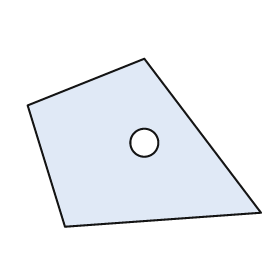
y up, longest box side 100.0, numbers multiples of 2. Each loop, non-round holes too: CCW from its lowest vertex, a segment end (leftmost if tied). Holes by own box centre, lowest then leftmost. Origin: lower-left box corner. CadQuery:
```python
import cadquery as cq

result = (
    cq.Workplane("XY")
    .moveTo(16.0, 0.0)
    .lineTo(100.0, 6.0)
    .lineTo(50.0, 72.0)
    .lineTo(0.0, 52.0)
    .close()
    .moveTo(50.0, 36.0)
    .circle(6.0)
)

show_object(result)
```